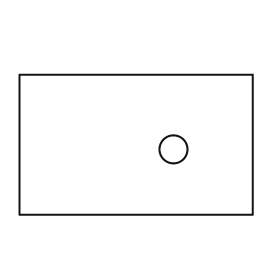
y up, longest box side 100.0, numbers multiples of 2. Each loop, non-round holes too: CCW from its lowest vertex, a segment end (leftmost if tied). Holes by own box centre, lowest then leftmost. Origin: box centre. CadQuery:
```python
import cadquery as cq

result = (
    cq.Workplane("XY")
    .moveTo(-50.0, -30.0)
    .lineTo(50.0, -30.0)
    .lineTo(50.0, 30.0)
    .lineTo(-50.0, 30.0)
    .close()
    .moveTo(16.0, -2.0)
    .circle(6.0)
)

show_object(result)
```